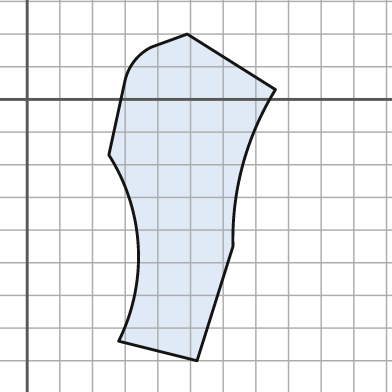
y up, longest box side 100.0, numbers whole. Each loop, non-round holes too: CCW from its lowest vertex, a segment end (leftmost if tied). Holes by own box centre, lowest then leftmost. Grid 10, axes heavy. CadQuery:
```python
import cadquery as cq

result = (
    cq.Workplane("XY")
    .moveTo(52.0, -80.0)
    .lineTo(63.0, -45.0)
    .threePointArc((66.0, -20.0), (76.0, 3.0))
    .lineTo(49.0, 20.0)
    .lineTo(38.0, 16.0)
    .threePointArc((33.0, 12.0), (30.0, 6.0))
    .lineTo(25.0, -17.0)
    .threePointArc((34.0, -45.0), (28.0, -74.0))
    .close()
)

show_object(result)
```